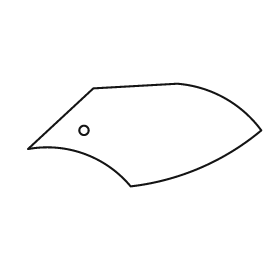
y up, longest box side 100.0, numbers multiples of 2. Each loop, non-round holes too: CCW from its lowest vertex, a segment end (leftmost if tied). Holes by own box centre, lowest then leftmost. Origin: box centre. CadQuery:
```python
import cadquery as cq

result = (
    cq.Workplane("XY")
    .moveTo(-6.0, -22.0)
    .threePointArc((24.0, -14.0), (50.0, 2.0))
    .threePointArc((34.0, 16.0), (14.0, 22.0))
    .lineTo(-22.0, 20.0)
    .lineTo(-50.0, -6.0)
    .threePointArc((-26.0, -8.0), (-6.0, -22.0))
    .close()
    .moveTo(-26.0, 2.0)
    .circle(2.0)
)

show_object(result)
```